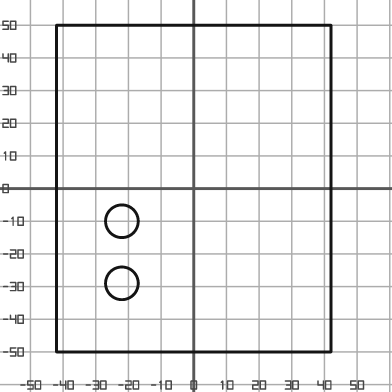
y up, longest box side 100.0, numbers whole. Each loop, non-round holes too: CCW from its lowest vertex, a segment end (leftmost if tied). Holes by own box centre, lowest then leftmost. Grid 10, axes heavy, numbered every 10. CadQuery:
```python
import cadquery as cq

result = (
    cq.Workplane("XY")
    .moveTo(-42.0, -50.0)
    .lineTo(42.0, -50.0)
    .lineTo(42.0, 50.0)
    .lineTo(-42.0, 50.0)
    .close()
    .moveTo(-22.0, -29.0)
    .circle(5.0)
    .moveTo(-22.0, -10.0)
    .circle(5.0)
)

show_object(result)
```